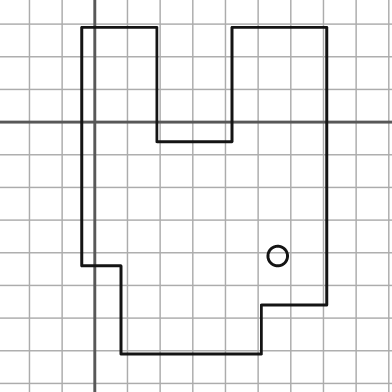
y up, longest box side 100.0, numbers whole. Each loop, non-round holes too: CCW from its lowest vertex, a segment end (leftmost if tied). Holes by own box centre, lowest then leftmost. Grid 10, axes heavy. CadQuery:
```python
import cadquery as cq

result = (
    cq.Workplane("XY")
    .moveTo(8.0, -71.0)
    .lineTo(51.0, -71.0)
    .lineTo(51.0, -56.0)
    .lineTo(71.0, -56.0)
    .lineTo(71.0, 29.0)
    .lineTo(42.0, 29.0)
    .lineTo(42.0, -6.0)
    .lineTo(19.0, -6.0)
    .lineTo(19.0, 29.0)
    .lineTo(-4.0, 29.0)
    .lineTo(-4.0, -44.0)
    .lineTo(8.0, -44.0)
    .close()
    .moveTo(56.0, -41.0)
    .circle(3.0)
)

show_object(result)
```